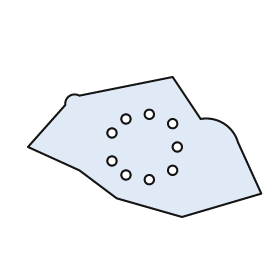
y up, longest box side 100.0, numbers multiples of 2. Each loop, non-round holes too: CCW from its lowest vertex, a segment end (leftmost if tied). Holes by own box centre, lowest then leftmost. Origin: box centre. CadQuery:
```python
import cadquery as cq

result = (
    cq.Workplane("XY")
    .moveTo(16.0, -30.0)
    .lineTo(50.0, -20.0)
    .lineTo(40.0, 2.0)
    .threePointArc((34.0, 10.0), (24.0, 12.0))
    .lineTo(12.0, 30.0)
    .lineTo(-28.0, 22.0)
    .threePointArc((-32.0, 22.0), (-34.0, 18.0))
    .lineTo(-50.0, 0.0)
    .lineTo(-28.0, -10.0)
    .lineTo(-12.0, -22.0)
    .close()
    .moveTo(2.0, -14.0)
    .circle(2.0)
    .moveTo(-8.0, -12.0)
    .circle(2.0)
    .moveTo(12.0, -10.0)
    .circle(2.0)
    .moveTo(-14.0, -6.0)
    .circle(2.0)
    .moveTo(14.0, 0.0)
    .circle(2.0)
    .moveTo(-14.0, 6.0)
    .circle(2.0)
    .moveTo(12.0, 10.0)
    .circle(2.0)
    .moveTo(-8.0, 12.0)
    .circle(2.0)
    .moveTo(2.0, 14.0)
    .circle(2.0)
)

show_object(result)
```